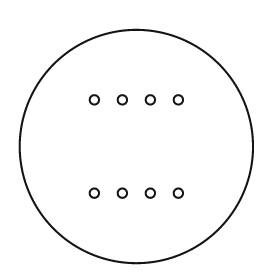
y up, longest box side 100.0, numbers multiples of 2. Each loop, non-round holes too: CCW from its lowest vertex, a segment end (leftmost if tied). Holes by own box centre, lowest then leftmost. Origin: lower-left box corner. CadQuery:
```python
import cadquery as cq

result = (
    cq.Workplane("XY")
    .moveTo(50.0, 50.0)
    .circle(50.0)
    .moveTo(32.0, 30.0)
    .circle(2.0)
    .moveTo(44.0, 30.0)
    .circle(2.0)
    .moveTo(56.0, 30.0)
    .circle(2.0)
    .moveTo(68.0, 30.0)
    .circle(2.0)
    .moveTo(32.0, 70.0)
    .circle(2.0)
    .moveTo(44.0, 70.0)
    .circle(2.0)
    .moveTo(56.0, 70.0)
    .circle(2.0)
    .moveTo(68.0, 70.0)
    .circle(2.0)
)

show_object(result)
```